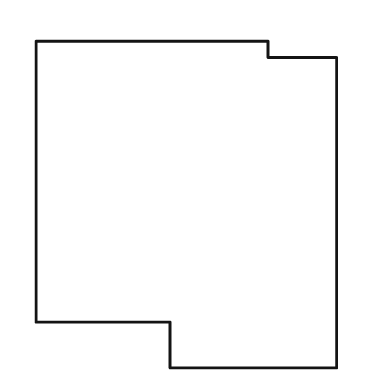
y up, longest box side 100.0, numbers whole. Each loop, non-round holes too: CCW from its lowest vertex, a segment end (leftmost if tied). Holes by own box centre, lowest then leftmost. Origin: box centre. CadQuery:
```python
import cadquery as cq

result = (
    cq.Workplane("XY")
    .moveTo(-5.0, -50.0)
    .lineTo(46.0, -50.0)
    .lineTo(46.0, 45.0)
    .lineTo(25.0, 45.0)
    .lineTo(25.0, 50.0)
    .lineTo(-46.0, 50.0)
    .lineTo(-46.0, -36.0)
    .lineTo(-5.0, -36.0)
    .close()
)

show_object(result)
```